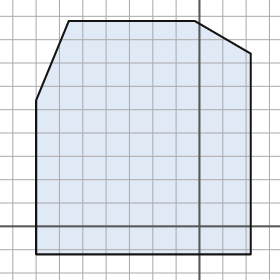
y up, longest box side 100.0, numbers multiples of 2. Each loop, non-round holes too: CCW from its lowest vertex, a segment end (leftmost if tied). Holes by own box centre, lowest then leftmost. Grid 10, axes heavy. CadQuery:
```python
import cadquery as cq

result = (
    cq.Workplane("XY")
    .moveTo(-70.0, -12.0)
    .lineTo(22.0, -12.0)
    .lineTo(22.0, 74.0)
    .lineTo(-2.0, 88.0)
    .lineTo(-56.0, 88.0)
    .lineTo(-70.0, 54.0)
    .close()
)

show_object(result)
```